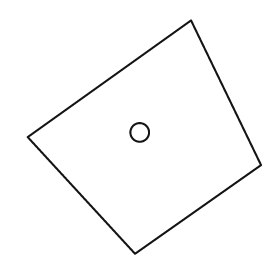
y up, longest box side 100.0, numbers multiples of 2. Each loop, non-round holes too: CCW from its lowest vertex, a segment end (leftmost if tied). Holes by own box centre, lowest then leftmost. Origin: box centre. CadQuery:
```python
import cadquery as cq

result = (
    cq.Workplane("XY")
    .moveTo(-4.0, -50.0)
    .lineTo(50.0, -12.0)
    .lineTo(20.0, 50.0)
    .lineTo(-50.0, 0.0)
    .close()
    .moveTo(-2.0, 2.0)
    .circle(4.0)
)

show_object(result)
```